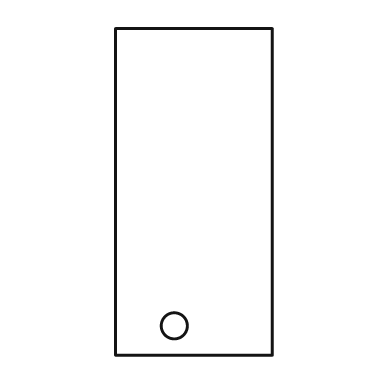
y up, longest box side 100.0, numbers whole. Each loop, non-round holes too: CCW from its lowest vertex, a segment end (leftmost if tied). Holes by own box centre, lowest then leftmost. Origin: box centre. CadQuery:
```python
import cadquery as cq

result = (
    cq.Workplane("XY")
    .moveTo(-24.0, -50.0)
    .lineTo(24.0, -50.0)
    .lineTo(24.0, 50.0)
    .lineTo(-24.0, 50.0)
    .close()
    .moveTo(-6.0, -41.0)
    .circle(4.0)
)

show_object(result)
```